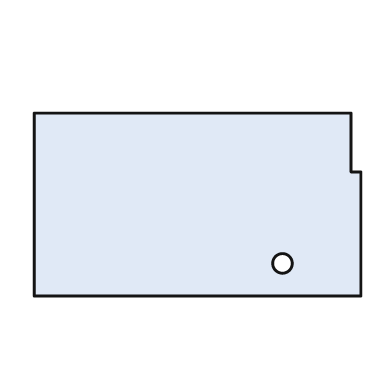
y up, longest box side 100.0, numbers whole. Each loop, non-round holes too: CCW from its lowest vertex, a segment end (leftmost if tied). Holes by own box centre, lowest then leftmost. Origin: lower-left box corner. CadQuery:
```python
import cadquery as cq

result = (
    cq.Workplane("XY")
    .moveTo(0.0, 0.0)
    .lineTo(100.0, 0.0)
    .lineTo(100.0, 38.0)
    .lineTo(97.0, 38.0)
    .lineTo(97.0, 56.0)
    .lineTo(0.0, 56.0)
    .close()
    .moveTo(76.0, 10.0)
    .circle(3.0)
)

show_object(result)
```